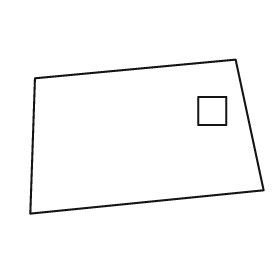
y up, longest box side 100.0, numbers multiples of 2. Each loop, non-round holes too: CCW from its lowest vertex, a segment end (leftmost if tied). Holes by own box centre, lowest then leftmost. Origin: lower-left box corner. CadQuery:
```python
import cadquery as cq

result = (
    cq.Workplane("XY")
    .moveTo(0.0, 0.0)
    .lineTo(100.0, 10.0)
    .lineTo(88.0, 66.0)
    .lineTo(2.0, 58.0)
    .close()
    .moveTo(72.0, 38.0)
    .lineTo(84.0, 38.0)
    .lineTo(84.0, 50.0)
    .lineTo(72.0, 50.0)
    .close()
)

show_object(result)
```